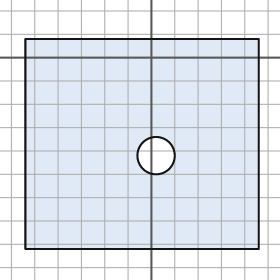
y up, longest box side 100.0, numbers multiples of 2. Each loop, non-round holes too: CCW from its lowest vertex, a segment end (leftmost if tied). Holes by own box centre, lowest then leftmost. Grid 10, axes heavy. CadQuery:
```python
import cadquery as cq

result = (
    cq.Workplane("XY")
    .moveTo(-54.0, -82.0)
    .lineTo(46.0, -82.0)
    .lineTo(46.0, 8.0)
    .lineTo(-54.0, 8.0)
    .close()
    .moveTo(2.0, -42.0)
    .circle(8.0)
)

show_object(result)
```